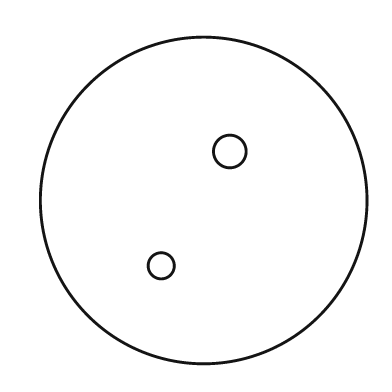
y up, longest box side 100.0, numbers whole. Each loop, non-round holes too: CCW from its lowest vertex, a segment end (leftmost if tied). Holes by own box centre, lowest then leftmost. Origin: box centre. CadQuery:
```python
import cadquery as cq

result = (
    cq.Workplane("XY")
    .moveTo(0.0, 0.0)
    .circle(50.0)
    .moveTo(-13.0, -20.0)
    .circle(4.0)
    .moveTo(8.0, 15.0)
    .circle(5.0)
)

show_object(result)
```